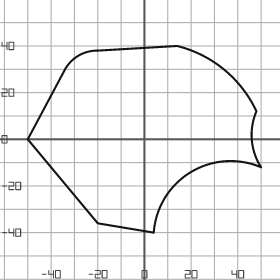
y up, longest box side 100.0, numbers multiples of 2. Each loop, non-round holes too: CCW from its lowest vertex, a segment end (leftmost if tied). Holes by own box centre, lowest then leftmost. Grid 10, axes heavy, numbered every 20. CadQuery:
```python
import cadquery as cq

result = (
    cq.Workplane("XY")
    .moveTo(4.0, -40.0)
    .threePointArc((20.0, -14.0), (50.0, -12.0))
    .threePointArc((46.0, 0.0), (48.0, 12.0))
    .threePointArc((34.0, 30.0), (14.0, 40.0))
    .lineTo(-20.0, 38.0)
    .threePointArc((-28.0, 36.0), (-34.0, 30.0))
    .lineTo(-50.0, 0.0)
    .lineTo(-20.0, -36.0)
    .close()
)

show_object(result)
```